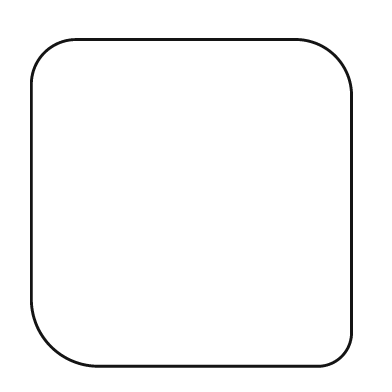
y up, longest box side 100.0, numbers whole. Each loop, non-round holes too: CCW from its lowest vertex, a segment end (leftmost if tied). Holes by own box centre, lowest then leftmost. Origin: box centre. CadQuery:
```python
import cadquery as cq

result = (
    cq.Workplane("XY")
    .moveTo(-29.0, -50.0)
    .lineTo(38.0, -50.0)
    .threePointArc((46.0, -47.0), (49.0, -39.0))
    .lineTo(49.0, 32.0)
    .threePointArc((44.0, 45.0), (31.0, 50.0))
    .lineTo(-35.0, 50.0)
    .threePointArc((-45.0, 46.0), (-49.0, 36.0))
    .lineTo(-49.0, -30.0)
    .threePointArc((-43.0, -44.0), (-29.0, -50.0))
    .close()
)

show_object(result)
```